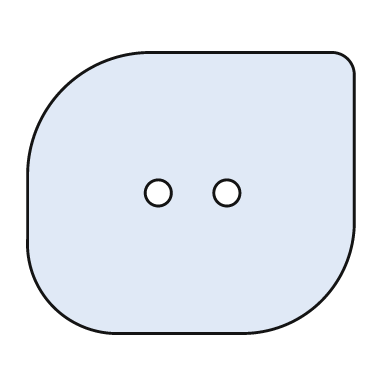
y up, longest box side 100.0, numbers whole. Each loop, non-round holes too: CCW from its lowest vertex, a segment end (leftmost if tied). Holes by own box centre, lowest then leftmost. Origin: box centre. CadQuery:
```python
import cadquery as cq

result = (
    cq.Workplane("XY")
    .moveTo(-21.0, -43.0)
    .lineTo(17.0, -43.0)
    .threePointArc((40.0, -33.0), (50.0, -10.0))
    .lineTo(50.0, 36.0)
    .threePointArc((48.0, 41.0), (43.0, 43.0))
    .lineTo(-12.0, 43.0)
    .threePointArc((-39.0, 32.0), (-50.0, 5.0))
    .lineTo(-50.0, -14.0)
    .threePointArc((-42.0, -35.0), (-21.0, -43.0))
    .close()
    .moveTo(-10.0, 0.0)
    .circle(4.0)
    .moveTo(11.0, 0.0)
    .circle(4.0)
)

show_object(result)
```